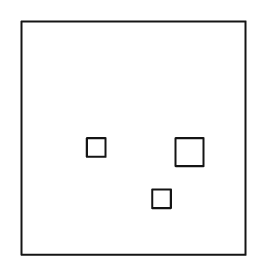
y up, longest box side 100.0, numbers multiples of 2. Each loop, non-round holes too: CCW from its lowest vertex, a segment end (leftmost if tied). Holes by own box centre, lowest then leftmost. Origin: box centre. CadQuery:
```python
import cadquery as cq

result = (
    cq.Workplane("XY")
    .moveTo(-48.0, -50.0)
    .lineTo(48.0, -50.0)
    .lineTo(48.0, 50.0)
    .lineTo(-48.0, 50.0)
    .close()
    .moveTo(8.0, -30.0)
    .lineTo(16.0, -30.0)
    .lineTo(16.0, -22.0)
    .lineTo(8.0, -22.0)
    .close()
    .moveTo(18.0, -12.0)
    .lineTo(30.0, -12.0)
    .lineTo(30.0, 0.0)
    .lineTo(18.0, 0.0)
    .close()
    .moveTo(-20.0, -8.0)
    .lineTo(-12.0, -8.0)
    .lineTo(-12.0, 0.0)
    .lineTo(-20.0, 0.0)
    .close()
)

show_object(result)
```